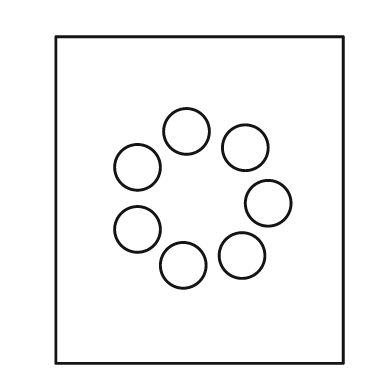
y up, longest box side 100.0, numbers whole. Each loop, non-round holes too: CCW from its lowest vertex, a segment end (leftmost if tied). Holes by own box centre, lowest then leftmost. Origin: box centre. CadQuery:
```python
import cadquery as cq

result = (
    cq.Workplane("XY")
    .moveTo(-44.0, -50.0)
    .lineTo(44.0, -50.0)
    .lineTo(44.0, 50.0)
    .lineTo(-44.0, 50.0)
    .close()
    .moveTo(-5.0, -20.0)
    .circle(7.0)
    .moveTo(13.0, -17.0)
    .circle(7.0)
    .moveTo(-19.0, -9.0)
    .circle(7.0)
    .moveTo(21.0, -1.0)
    .circle(7.0)
    .moveTo(-19.0, 10.0)
    .circle(7.0)
    .moveTo(14.0, 16.0)
    .circle(7.0)
    .moveTo(-4.0, 21.0)
    .circle(7.0)
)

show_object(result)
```